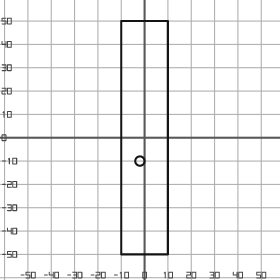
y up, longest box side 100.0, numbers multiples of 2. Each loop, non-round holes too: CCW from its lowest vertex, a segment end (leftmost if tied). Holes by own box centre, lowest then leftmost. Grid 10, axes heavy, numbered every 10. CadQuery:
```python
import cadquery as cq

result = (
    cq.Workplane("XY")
    .moveTo(-10.0, -50.0)
    .lineTo(10.0, -50.0)
    .lineTo(10.0, 50.0)
    .lineTo(-10.0, 50.0)
    .close()
    .moveTo(-2.0, -10.0)
    .circle(2.0)
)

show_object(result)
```